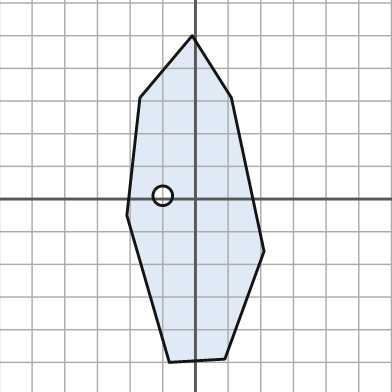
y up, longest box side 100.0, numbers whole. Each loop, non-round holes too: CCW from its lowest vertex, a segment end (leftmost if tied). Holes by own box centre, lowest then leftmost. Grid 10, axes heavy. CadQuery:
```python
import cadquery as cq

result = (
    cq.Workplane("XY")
    .moveTo(-8.0, -50.0)
    .lineTo(9.0, -49.0)
    .lineTo(21.0, -16.0)
    .lineTo(11.0, 31.0)
    .lineTo(-1.0, 50.0)
    .lineTo(-17.0, 31.0)
    .lineTo(-21.0, -5.0)
    .close()
    .moveTo(-10.0, 1.0)
    .circle(3.0)
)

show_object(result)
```